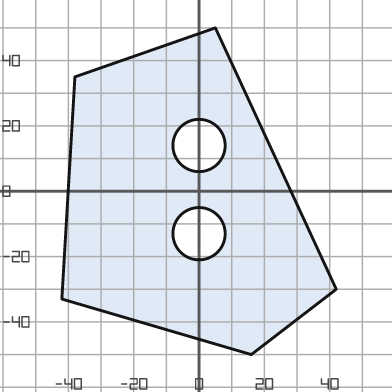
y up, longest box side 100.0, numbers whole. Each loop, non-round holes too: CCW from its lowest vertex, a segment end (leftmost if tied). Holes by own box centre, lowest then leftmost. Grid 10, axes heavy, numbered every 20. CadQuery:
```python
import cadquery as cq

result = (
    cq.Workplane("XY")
    .moveTo(16.0, -50.0)
    .lineTo(42.0, -30.0)
    .lineTo(5.0, 50.0)
    .lineTo(-38.0, 35.0)
    .lineTo(-42.0, -33.0)
    .close()
    .moveTo(0.0, -13.0)
    .circle(8.0)
    .moveTo(0.0, 14.0)
    .circle(8.0)
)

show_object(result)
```